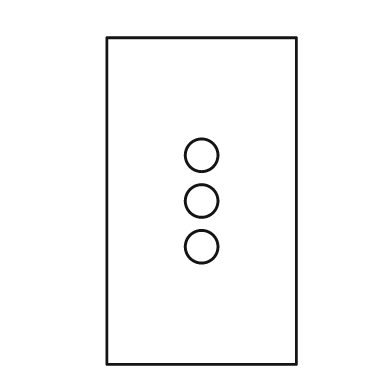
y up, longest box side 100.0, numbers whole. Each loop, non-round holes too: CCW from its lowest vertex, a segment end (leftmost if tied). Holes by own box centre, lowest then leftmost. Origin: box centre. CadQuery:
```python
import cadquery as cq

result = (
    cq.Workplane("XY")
    .moveTo(-29.0, -50.0)
    .lineTo(29.0, -50.0)
    .lineTo(29.0, 50.0)
    .lineTo(-29.0, 50.0)
    .close()
    .moveTo(0.0, -14.0)
    .circle(5.0)
    .moveTo(0.0, 0.0)
    .circle(5.0)
    .moveTo(0.0, 14.0)
    .circle(5.0)
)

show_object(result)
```